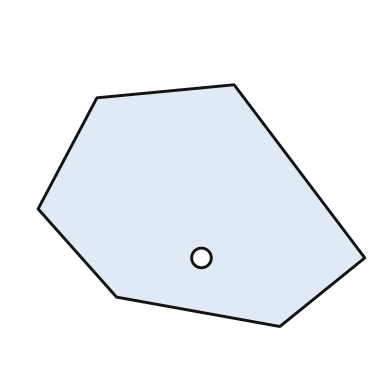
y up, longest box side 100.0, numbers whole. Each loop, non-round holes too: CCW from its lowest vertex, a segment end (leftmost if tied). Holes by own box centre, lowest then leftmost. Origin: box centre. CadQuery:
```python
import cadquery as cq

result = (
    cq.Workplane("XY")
    .moveTo(24.0, -37.0)
    .lineTo(50.0, -16.0)
    .lineTo(10.0, 37.0)
    .lineTo(-32.0, 33.0)
    .lineTo(-50.0, -1.0)
    .lineTo(-26.0, -28.0)
    .close()
    .moveTo(0.0, -16.0)
    .circle(3.0)
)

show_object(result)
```